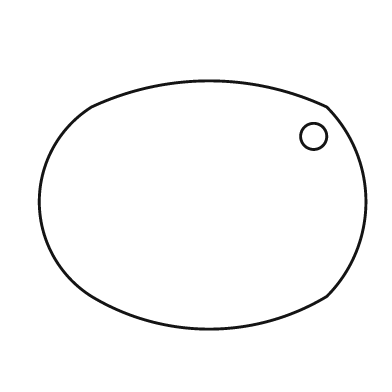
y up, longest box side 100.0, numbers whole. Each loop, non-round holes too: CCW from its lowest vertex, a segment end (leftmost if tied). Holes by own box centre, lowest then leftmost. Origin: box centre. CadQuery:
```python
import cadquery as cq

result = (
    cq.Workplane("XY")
    .moveTo(-34.0, -28.0)
    .threePointArc((2.0, -38.0), (38.0, -28.0))
    .threePointArc((50.0, 1.0), (38.0, 30.0))
    .threePointArc((2.0, 38.0), (-34.0, 30.0))
    .threePointArc((-50.0, 1.0), (-34.0, -28.0))
    .close()
    .moveTo(34.0, 21.0)
    .circle(4.0)
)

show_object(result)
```